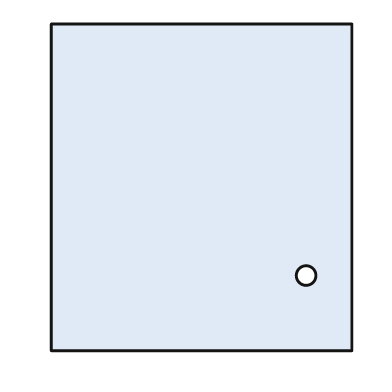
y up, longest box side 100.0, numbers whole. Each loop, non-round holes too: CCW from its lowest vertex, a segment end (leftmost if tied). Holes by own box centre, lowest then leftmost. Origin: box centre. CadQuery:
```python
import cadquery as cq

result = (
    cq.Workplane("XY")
    .moveTo(-46.0, -50.0)
    .lineTo(46.0, -50.0)
    .lineTo(46.0, 50.0)
    .lineTo(-46.0, 50.0)
    .close()
    .moveTo(32.0, -27.0)
    .circle(3.0)
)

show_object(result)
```